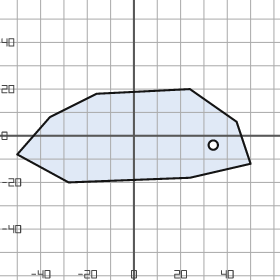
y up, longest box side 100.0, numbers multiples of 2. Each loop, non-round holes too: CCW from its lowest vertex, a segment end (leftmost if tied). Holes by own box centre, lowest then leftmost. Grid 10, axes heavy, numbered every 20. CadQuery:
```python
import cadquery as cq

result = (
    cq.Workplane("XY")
    .moveTo(-28.0, -20.0)
    .lineTo(24.0, -18.0)
    .lineTo(50.0, -12.0)
    .lineTo(44.0, 6.0)
    .lineTo(24.0, 20.0)
    .lineTo(-16.0, 18.0)
    .lineTo(-36.0, 8.0)
    .lineTo(-50.0, -8.0)
    .close()
    .moveTo(34.0, -4.0)
    .circle(2.0)
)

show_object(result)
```